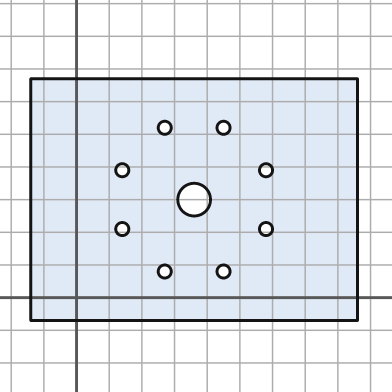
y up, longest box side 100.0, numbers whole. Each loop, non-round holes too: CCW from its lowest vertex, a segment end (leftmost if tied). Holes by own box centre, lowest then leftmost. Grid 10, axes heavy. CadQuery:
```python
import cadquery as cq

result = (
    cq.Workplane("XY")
    .moveTo(-14.0, -7.0)
    .lineTo(86.0, -7.0)
    .lineTo(86.0, 67.0)
    .lineTo(-14.0, 67.0)
    .close()
    .moveTo(27.0, 8.0)
    .circle(2.0)
    .moveTo(45.0, 8.0)
    .circle(2.0)
    .moveTo(14.0, 21.0)
    .circle(2.0)
    .moveTo(58.0, 21.0)
    .circle(2.0)
    .moveTo(36.0, 30.0)
    .circle(5.0)
    .moveTo(14.0, 39.0)
    .circle(2.0)
    .moveTo(58.0, 39.0)
    .circle(2.0)
    .moveTo(27.0, 52.0)
    .circle(2.0)
    .moveTo(45.0, 52.0)
    .circle(2.0)
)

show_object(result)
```